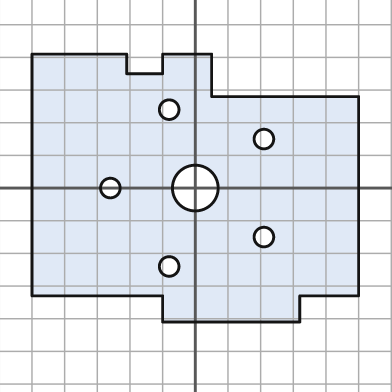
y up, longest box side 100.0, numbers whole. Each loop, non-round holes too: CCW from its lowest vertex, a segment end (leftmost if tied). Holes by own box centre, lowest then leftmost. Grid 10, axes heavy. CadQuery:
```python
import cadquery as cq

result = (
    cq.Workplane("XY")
    .moveTo(-10.0, -41.0)
    .lineTo(32.0, -41.0)
    .lineTo(32.0, -33.0)
    .lineTo(50.0, -33.0)
    .lineTo(50.0, 28.0)
    .lineTo(5.0, 28.0)
    .lineTo(5.0, 41.0)
    .lineTo(-10.0, 41.0)
    .lineTo(-10.0, 35.0)
    .lineTo(-21.0, 35.0)
    .lineTo(-21.0, 41.0)
    .lineTo(-50.0, 41.0)
    .lineTo(-50.0, -33.0)
    .lineTo(-10.0, -33.0)
    .close()
    .moveTo(-8.0, -24.0)
    .circle(3.0)
    .moveTo(21.0, -15.0)
    .circle(3.0)
    .moveTo(-26.0, 0.0)
    .circle(3.0)
    .moveTo(0.0, 0.0)
    .circle(7.0)
    .moveTo(21.0, 15.0)
    .circle(3.0)
    .moveTo(-8.0, 24.0)
    .circle(3.0)
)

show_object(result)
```